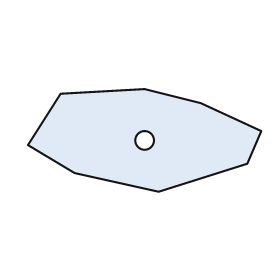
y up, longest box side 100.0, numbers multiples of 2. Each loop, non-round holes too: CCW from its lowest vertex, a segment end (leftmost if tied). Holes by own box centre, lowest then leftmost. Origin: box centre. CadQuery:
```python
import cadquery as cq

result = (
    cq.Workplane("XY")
    .moveTo(6.0, -22.0)
    .lineTo(44.0, -10.0)
    .lineTo(50.0, 4.0)
    .lineTo(24.0, 16.0)
    .lineTo(0.0, 22.0)
    .lineTo(-36.0, 20.0)
    .lineTo(-50.0, -2.0)
    .lineTo(-30.0, -14.0)
    .close()
    .moveTo(0.0, 0.0)
    .circle(4.0)
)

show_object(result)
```